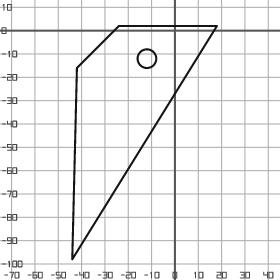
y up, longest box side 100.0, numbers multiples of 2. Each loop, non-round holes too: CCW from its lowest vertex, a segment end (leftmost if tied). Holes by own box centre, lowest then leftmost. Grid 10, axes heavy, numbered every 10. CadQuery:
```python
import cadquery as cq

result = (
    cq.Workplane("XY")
    .moveTo(-44.0, -98.0)
    .lineTo(18.0, 2.0)
    .lineTo(-24.0, 2.0)
    .lineTo(-42.0, -16.0)
    .close()
    .moveTo(-12.0, -12.0)
    .circle(4.0)
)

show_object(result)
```